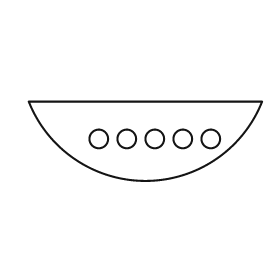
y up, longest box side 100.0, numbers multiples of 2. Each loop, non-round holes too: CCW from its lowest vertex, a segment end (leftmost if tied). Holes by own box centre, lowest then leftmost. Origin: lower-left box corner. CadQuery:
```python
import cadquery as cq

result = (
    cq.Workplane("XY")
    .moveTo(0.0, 34.0)
    .threePointArc((50.0, 0.0), (100.0, 34.0))
    .close()
    .moveTo(30.0, 18.0)
    .circle(4.0)
    .moveTo(42.0, 18.0)
    .circle(4.0)
    .moveTo(54.0, 18.0)
    .circle(4.0)
    .moveTo(66.0, 18.0)
    .circle(4.0)
    .moveTo(78.0, 18.0)
    .circle(4.0)
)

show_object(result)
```